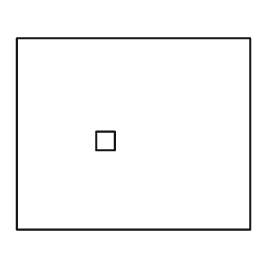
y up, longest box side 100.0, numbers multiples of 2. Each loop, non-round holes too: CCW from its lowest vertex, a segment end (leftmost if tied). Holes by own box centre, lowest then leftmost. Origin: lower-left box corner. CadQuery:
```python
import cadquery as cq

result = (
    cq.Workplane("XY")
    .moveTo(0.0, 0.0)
    .lineTo(100.0, 0.0)
    .lineTo(100.0, 82.0)
    .lineTo(0.0, 82.0)
    .close()
    .moveTo(34.0, 34.0)
    .lineTo(42.0, 34.0)
    .lineTo(42.0, 42.0)
    .lineTo(34.0, 42.0)
    .close()
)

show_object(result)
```